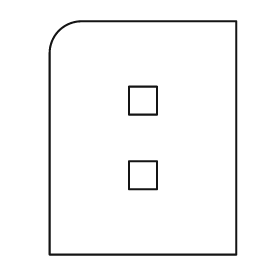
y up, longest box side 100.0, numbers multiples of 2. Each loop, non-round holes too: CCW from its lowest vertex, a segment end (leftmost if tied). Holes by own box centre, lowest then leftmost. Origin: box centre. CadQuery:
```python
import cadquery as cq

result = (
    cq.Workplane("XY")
    .moveTo(-40.0, -50.0)
    .lineTo(40.0, -50.0)
    .lineTo(40.0, 50.0)
    .lineTo(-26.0, 50.0)
    .threePointArc((-36.0, 46.0), (-40.0, 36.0))
    .close()
    .moveTo(-6.0, -22.0)
    .lineTo(6.0, -22.0)
    .lineTo(6.0, -10.0)
    .lineTo(-6.0, -10.0)
    .close()
    .moveTo(-6.0, 10.0)
    .lineTo(6.0, 10.0)
    .lineTo(6.0, 22.0)
    .lineTo(-6.0, 22.0)
    .close()
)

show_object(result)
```